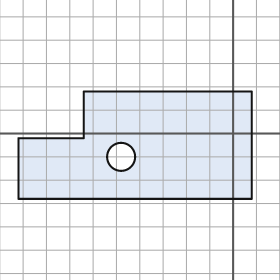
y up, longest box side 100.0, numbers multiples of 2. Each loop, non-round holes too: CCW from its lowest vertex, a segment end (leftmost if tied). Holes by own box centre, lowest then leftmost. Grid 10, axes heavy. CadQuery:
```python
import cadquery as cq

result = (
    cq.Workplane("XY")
    .moveTo(-92.0, -28.0)
    .lineTo(8.0, -28.0)
    .lineTo(8.0, 18.0)
    .lineTo(-64.0, 18.0)
    .lineTo(-64.0, -2.0)
    .lineTo(-92.0, -2.0)
    .close()
    .moveTo(-48.0, -10.0)
    .circle(6.0)
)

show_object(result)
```